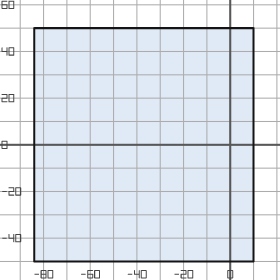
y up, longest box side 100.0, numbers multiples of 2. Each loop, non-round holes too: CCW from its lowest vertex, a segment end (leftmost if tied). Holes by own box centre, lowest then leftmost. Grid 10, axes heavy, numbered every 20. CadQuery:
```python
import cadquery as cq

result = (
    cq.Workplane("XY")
    .moveTo(-84.0, -50.0)
    .lineTo(10.0, -50.0)
    .lineTo(10.0, 50.0)
    .lineTo(-84.0, 50.0)
    .close()
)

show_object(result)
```